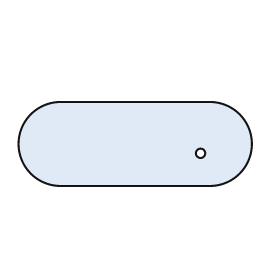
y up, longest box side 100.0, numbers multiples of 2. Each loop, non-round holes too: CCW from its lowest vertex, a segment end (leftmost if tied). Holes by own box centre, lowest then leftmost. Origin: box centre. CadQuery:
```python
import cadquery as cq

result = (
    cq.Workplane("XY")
    .moveTo(-32.0, -18.0)
    .lineTo(32.0, -18.0)
    .threePointArc((50.0, 0.0), (32.0, 18.0))
    .lineTo(-32.0, 18.0)
    .threePointArc((-50.0, 0.0), (-32.0, -18.0))
    .close()
    .moveTo(28.0, -4.0)
    .circle(2.0)
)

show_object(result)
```